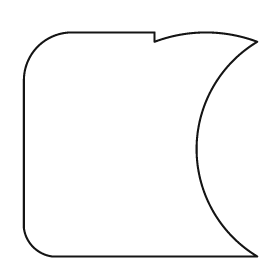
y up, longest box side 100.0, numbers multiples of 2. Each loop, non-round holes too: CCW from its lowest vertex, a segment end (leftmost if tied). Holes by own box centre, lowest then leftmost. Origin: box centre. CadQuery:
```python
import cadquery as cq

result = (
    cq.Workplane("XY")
    .moveTo(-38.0, -48.0)
    .lineTo(50.0, -48.0)
    .threePointArc((24.0, -2.0), (50.0, 44.0))
    .threePointArc((28.0, 48.0), (6.0, 44.0))
    .lineTo(6.0, 48.0)
    .lineTo(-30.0, 48.0)
    .threePointArc((-44.0, 42.0), (-50.0, 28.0))
    .lineTo(-50.0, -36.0)
    .threePointArc((-46.0, -44.0), (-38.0, -48.0))
    .close()
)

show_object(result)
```